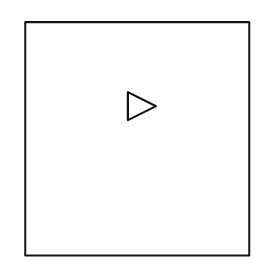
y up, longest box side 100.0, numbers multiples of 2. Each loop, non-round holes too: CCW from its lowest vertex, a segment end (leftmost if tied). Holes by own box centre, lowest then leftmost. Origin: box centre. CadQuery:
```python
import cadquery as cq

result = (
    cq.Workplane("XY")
    .moveTo(-48.0, -50.0)
    .lineTo(48.0, -50.0)
    .lineTo(48.0, 50.0)
    .lineTo(-48.0, 50.0)
    .close()
    .moveTo(-4.0, 8.0)
    .lineTo(8.0, 14.0)
    .lineTo(-4.0, 20.0)
    .close()
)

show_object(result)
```